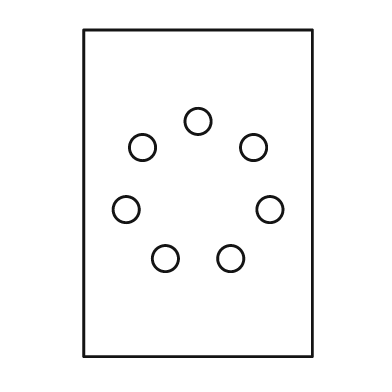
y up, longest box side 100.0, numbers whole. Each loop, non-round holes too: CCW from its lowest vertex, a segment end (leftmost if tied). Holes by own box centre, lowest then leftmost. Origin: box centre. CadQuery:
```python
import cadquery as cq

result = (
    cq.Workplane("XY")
    .moveTo(-35.0, -50.0)
    .lineTo(35.0, -50.0)
    .lineTo(35.0, 50.0)
    .lineTo(-35.0, 50.0)
    .close()
    .moveTo(-10.0, -20.0)
    .circle(4.0)
    .moveTo(10.0, -20.0)
    .circle(4.0)
    .moveTo(-22.0, -5.0)
    .circle(4.0)
    .moveTo(22.0, -5.0)
    .circle(4.0)
    .moveTo(-17.0, 14.0)
    .circle(4.0)
    .moveTo(17.0, 14.0)
    .circle(4.0)
    .moveTo(0.0, 22.0)
    .circle(4.0)
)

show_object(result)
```